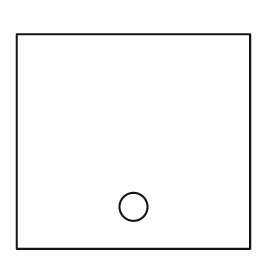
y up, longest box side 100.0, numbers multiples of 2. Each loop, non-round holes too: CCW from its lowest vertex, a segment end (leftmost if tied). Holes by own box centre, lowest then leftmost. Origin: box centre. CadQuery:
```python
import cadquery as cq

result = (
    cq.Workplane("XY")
    .moveTo(-50.0, -46.0)
    .lineTo(50.0, -46.0)
    .lineTo(50.0, 46.0)
    .lineTo(-50.0, 46.0)
    .close()
    .moveTo(0.0, -28.0)
    .circle(6.0)
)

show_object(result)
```